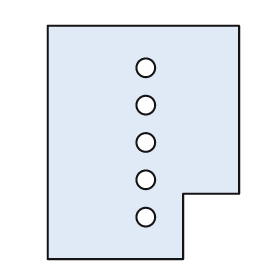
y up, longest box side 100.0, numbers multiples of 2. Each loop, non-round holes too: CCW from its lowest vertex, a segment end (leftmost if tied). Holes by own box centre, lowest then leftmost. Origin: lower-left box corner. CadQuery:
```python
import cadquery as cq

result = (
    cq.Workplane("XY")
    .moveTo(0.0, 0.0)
    .lineTo(58.0, 0.0)
    .lineTo(58.0, 28.0)
    .lineTo(82.0, 28.0)
    .lineTo(82.0, 100.0)
    .lineTo(0.0, 100.0)
    .close()
    .moveTo(42.0, 18.0)
    .circle(4.0)
    .moveTo(42.0, 34.0)
    .circle(4.0)
    .moveTo(42.0, 50.0)
    .circle(4.0)
    .moveTo(42.0, 66.0)
    .circle(4.0)
    .moveTo(42.0, 82.0)
    .circle(4.0)
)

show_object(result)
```